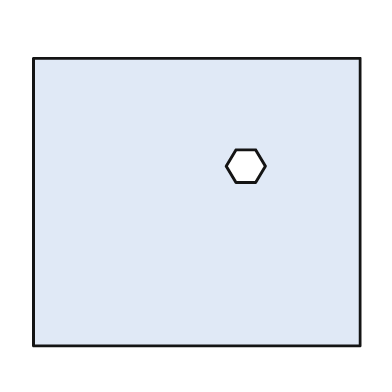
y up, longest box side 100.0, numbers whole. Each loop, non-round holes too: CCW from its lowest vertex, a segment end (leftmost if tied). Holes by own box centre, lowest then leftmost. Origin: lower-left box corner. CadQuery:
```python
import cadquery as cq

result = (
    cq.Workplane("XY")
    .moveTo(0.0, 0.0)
    .lineTo(100.0, 0.0)
    .lineTo(100.0, 88.0)
    .lineTo(0.0, 88.0)
    .close()
    .moveTo(62.0, 50.0)
    .lineTo(68.0, 50.0)
    .lineTo(71.0, 55.0)
    .lineTo(68.0, 60.0)
    .lineTo(62.0, 60.0)
    .lineTo(59.0, 55.0)
    .close()
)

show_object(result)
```